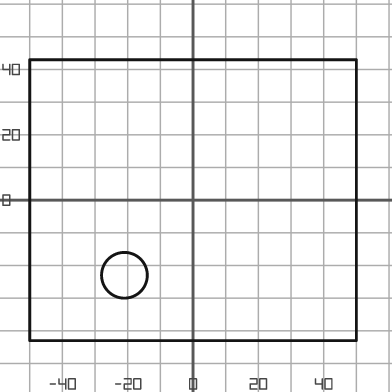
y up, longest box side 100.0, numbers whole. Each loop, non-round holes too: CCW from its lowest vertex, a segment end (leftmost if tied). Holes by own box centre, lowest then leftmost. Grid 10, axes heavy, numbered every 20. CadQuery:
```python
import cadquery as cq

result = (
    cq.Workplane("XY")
    .moveTo(-50.0, -43.0)
    .lineTo(50.0, -43.0)
    .lineTo(50.0, 43.0)
    .lineTo(-50.0, 43.0)
    .close()
    .moveTo(-21.0, -23.0)
    .circle(7.0)
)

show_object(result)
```